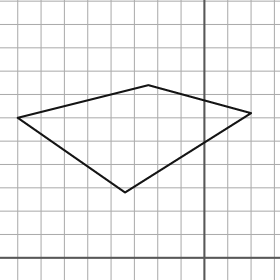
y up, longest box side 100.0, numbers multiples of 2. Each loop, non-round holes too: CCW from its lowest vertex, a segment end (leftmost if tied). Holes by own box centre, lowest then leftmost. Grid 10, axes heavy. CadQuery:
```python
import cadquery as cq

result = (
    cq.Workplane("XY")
    .moveTo(-34.0, 28.0)
    .lineTo(20.0, 62.0)
    .lineTo(-24.0, 74.0)
    .lineTo(-80.0, 60.0)
    .close()
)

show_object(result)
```